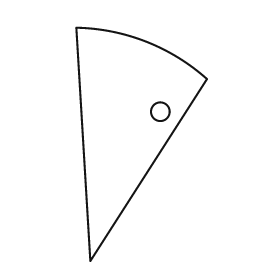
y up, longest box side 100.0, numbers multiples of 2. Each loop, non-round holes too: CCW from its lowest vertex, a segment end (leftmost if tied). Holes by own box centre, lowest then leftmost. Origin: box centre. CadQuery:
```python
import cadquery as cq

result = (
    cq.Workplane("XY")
    .moveTo(-22.0, -50.0)
    .lineTo(28.0, 28.0)
    .threePointArc((2.0, 44.0), (-28.0, 50.0))
    .close()
    .moveTo(8.0, 14.0)
    .circle(4.0)
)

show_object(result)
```